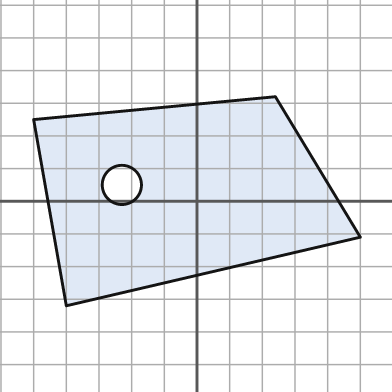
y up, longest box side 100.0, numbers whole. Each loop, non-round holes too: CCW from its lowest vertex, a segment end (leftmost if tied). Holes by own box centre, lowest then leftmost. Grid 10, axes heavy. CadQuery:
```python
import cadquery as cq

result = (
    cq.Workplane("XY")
    .moveTo(-40.0, -32.0)
    .lineTo(50.0, -11.0)
    .lineTo(24.0, 32.0)
    .lineTo(-50.0, 25.0)
    .close()
    .moveTo(-23.0, 5.0)
    .circle(6.0)
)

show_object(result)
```